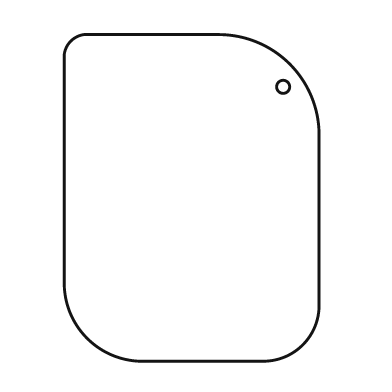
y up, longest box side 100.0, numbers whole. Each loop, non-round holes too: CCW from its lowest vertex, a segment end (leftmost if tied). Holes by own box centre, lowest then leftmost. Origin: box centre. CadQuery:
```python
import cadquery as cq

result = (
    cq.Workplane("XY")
    .moveTo(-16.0, -50.0)
    .lineTo(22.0, -50.0)
    .threePointArc((34.0, -45.0), (39.0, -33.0))
    .lineTo(39.0, 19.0)
    .threePointArc((30.0, 41.0), (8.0, 50.0))
    .lineTo(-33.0, 50.0)
    .threePointArc((-37.0, 48.0), (-39.0, 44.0))
    .lineTo(-39.0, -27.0)
    .threePointArc((-32.0, -43.0), (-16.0, -50.0))
    .close()
    .moveTo(28.0, 34.0)
    .circle(2.0)
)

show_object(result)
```